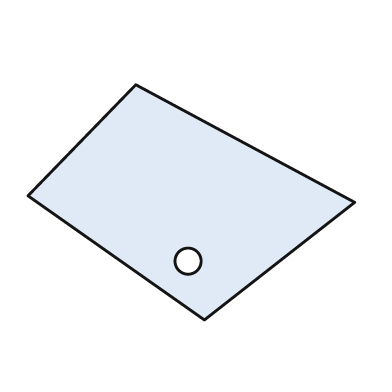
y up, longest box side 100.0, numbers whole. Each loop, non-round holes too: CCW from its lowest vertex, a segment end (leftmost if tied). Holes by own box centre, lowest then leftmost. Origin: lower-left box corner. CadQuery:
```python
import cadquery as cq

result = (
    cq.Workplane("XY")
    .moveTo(54.0, 0.0)
    .lineTo(100.0, 36.0)
    .lineTo(33.0, 72.0)
    .lineTo(0.0, 38.0)
    .close()
    .moveTo(49.0, 18.0)
    .circle(4.0)
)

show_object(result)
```